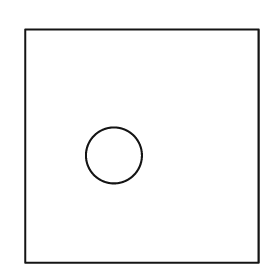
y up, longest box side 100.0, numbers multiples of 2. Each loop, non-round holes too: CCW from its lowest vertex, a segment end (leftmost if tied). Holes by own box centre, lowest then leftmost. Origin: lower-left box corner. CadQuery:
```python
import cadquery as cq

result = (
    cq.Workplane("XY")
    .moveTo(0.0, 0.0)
    .lineTo(100.0, 0.0)
    .lineTo(100.0, 100.0)
    .lineTo(0.0, 100.0)
    .close()
    .moveTo(38.0, 46.0)
    .circle(12.0)
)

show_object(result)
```